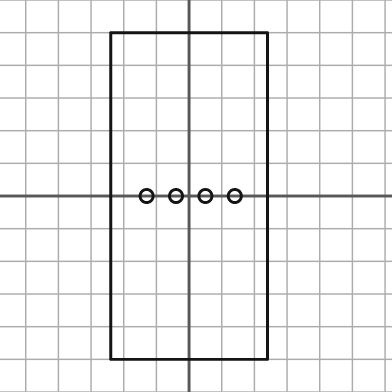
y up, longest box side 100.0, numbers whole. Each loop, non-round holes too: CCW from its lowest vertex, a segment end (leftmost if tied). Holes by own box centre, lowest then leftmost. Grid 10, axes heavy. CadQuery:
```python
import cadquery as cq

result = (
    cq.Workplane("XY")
    .moveTo(-24.0, -50.0)
    .lineTo(24.0, -50.0)
    .lineTo(24.0, 50.0)
    .lineTo(-24.0, 50.0)
    .close()
    .moveTo(-13.0, 0.0)
    .circle(2.0)
    .moveTo(-4.0, 0.0)
    .circle(2.0)
    .moveTo(5.0, 0.0)
    .circle(2.0)
    .moveTo(14.0, 0.0)
    .circle(2.0)
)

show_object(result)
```